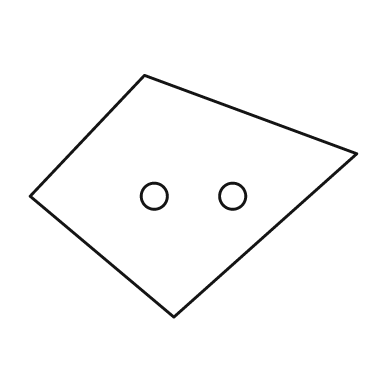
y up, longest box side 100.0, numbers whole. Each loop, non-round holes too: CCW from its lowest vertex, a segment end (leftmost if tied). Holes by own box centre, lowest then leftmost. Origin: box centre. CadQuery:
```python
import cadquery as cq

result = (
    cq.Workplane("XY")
    .moveTo(-6.0, -37.0)
    .lineTo(50.0, 13.0)
    .lineTo(-15.0, 37.0)
    .lineTo(-50.0, 0.0)
    .close()
    .moveTo(-12.0, 0.0)
    .circle(4.0)
    .moveTo(12.0, 0.0)
    .circle(4.0)
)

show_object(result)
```